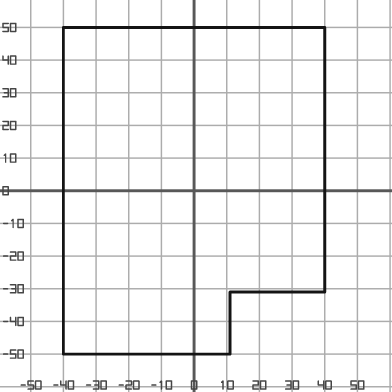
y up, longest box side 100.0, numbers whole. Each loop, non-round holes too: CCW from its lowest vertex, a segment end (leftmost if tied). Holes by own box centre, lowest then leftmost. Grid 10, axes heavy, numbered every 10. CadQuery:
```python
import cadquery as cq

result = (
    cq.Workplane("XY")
    .moveTo(-40.0, -50.0)
    .lineTo(11.0, -50.0)
    .lineTo(11.0, -31.0)
    .lineTo(40.0, -31.0)
    .lineTo(40.0, 50.0)
    .lineTo(-40.0, 50.0)
    .close()
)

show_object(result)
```